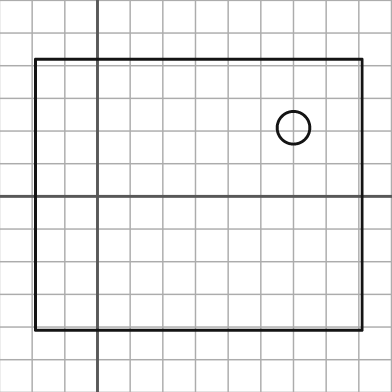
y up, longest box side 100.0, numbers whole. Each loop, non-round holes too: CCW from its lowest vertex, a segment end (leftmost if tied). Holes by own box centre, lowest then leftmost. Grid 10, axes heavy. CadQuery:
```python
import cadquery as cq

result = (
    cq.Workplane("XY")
    .moveTo(-19.0, -41.0)
    .lineTo(81.0, -41.0)
    .lineTo(81.0, 42.0)
    .lineTo(-19.0, 42.0)
    .close()
    .moveTo(60.0, 21.0)
    .circle(5.0)
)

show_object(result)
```